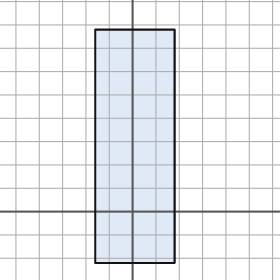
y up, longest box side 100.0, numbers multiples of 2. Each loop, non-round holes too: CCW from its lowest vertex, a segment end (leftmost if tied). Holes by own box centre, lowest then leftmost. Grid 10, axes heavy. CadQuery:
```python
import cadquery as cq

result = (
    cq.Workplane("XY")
    .moveTo(-16.0, -22.0)
    .lineTo(18.0, -22.0)
    .lineTo(18.0, 78.0)
    .lineTo(-16.0, 78.0)
    .close()
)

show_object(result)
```